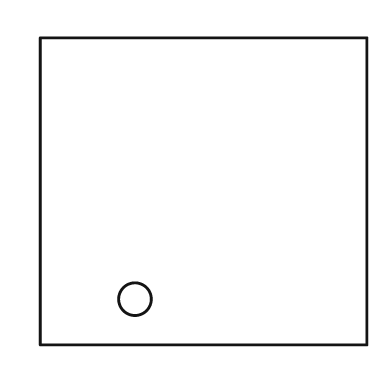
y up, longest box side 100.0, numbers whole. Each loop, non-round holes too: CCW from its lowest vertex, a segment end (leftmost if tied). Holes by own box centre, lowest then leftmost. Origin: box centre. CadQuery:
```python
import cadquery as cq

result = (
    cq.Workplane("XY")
    .moveTo(-50.0, -47.0)
    .lineTo(50.0, -47.0)
    .lineTo(50.0, 47.0)
    .lineTo(-50.0, 47.0)
    .close()
    .moveTo(-21.0, -33.0)
    .circle(5.0)
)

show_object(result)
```